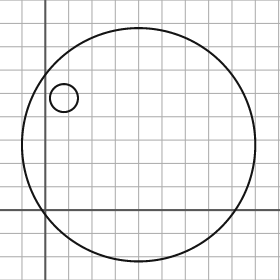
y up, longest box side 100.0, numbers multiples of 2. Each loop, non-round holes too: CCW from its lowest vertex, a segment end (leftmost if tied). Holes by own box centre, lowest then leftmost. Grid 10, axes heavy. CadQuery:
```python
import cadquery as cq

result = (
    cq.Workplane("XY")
    .moveTo(40.0, 28.0)
    .circle(50.0)
    .moveTo(8.0, 48.0)
    .circle(6.0)
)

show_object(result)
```